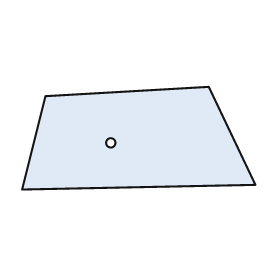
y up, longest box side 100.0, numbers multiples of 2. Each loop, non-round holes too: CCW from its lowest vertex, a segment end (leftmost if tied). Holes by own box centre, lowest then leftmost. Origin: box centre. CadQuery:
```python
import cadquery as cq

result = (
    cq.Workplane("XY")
    .moveTo(-50.0, -22.0)
    .lineTo(50.0, -20.0)
    .lineTo(30.0, 22.0)
    .lineTo(-40.0, 18.0)
    .close()
    .moveTo(-12.0, -2.0)
    .circle(2.0)
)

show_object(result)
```